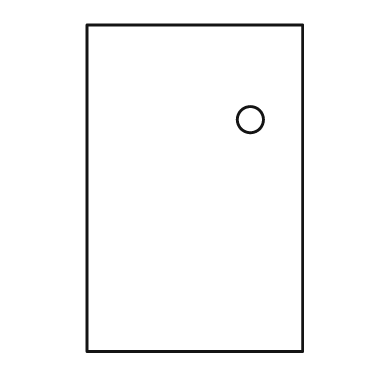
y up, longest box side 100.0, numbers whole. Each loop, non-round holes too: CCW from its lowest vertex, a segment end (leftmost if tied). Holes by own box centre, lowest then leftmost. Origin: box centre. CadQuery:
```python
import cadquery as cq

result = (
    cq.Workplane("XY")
    .moveTo(-33.0, -50.0)
    .lineTo(33.0, -50.0)
    .lineTo(33.0, 50.0)
    .lineTo(-33.0, 50.0)
    .close()
    .moveTo(17.0, 21.0)
    .circle(4.0)
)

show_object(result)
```